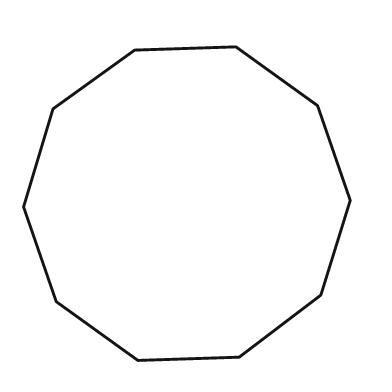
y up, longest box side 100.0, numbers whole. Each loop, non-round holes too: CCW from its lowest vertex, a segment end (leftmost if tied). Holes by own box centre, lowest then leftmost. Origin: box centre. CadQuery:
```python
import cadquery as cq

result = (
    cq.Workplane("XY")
    .moveTo(-15.0, -48.0)
    .lineTo(16.0, -47.0)
    .lineTo(41.0, -28.0)
    .lineTo(50.0, 1.0)
    .lineTo(40.0, 30.0)
    .lineTo(15.0, 48.0)
    .lineTo(-16.0, 47.0)
    .lineTo(-41.0, 29.0)
    .lineTo(-50.0, -1.0)
    .lineTo(-40.0, -30.0)
    .close()
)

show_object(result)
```